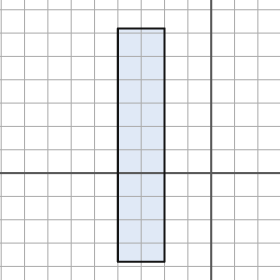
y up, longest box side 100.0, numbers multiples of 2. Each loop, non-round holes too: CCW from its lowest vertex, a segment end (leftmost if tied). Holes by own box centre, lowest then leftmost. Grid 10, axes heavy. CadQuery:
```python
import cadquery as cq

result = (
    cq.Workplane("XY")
    .moveTo(-40.0, -38.0)
    .lineTo(-20.0, -38.0)
    .lineTo(-20.0, 62.0)
    .lineTo(-40.0, 62.0)
    .close()
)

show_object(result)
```